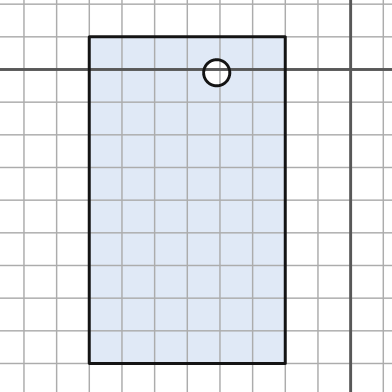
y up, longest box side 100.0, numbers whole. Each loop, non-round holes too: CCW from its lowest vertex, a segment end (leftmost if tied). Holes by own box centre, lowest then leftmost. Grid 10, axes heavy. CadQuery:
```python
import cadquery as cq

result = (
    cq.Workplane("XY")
    .moveTo(-80.0, -90.0)
    .lineTo(-20.0, -90.0)
    .lineTo(-20.0, 10.0)
    .lineTo(-80.0, 10.0)
    .close()
    .moveTo(-41.0, -1.0)
    .circle(4.0)
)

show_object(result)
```